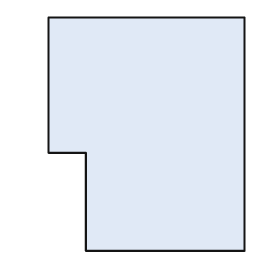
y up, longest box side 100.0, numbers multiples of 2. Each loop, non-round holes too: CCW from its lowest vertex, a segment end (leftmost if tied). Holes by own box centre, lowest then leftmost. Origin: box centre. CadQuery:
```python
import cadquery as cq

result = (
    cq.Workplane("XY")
    .moveTo(-26.0, -50.0)
    .lineTo(42.0, -50.0)
    .lineTo(42.0, 50.0)
    .lineTo(-42.0, 50.0)
    .lineTo(-42.0, -8.0)
    .lineTo(-26.0, -8.0)
    .close()
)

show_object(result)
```